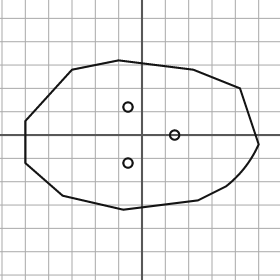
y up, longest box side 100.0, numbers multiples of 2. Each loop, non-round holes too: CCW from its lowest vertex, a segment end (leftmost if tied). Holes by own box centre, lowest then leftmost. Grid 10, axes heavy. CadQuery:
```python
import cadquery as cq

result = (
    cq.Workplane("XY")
    .moveTo(-8.0, -32.0)
    .lineTo(24.0, -28.0)
    .lineTo(36.0, -22.0)
    .threePointArc((44.0, -14.0), (50.0, -4.0))
    .lineTo(42.0, 20.0)
    .lineTo(22.0, 28.0)
    .lineTo(-10.0, 32.0)
    .lineTo(-30.0, 28.0)
    .lineTo(-50.0, 6.0)
    .lineTo(-50.0, -12.0)
    .lineTo(-34.0, -26.0)
    .close()
    .moveTo(-6.0, -12.0)
    .circle(2.0)
    .moveTo(14.0, 0.0)
    .circle(2.0)
    .moveTo(-6.0, 12.0)
    .circle(2.0)
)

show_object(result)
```